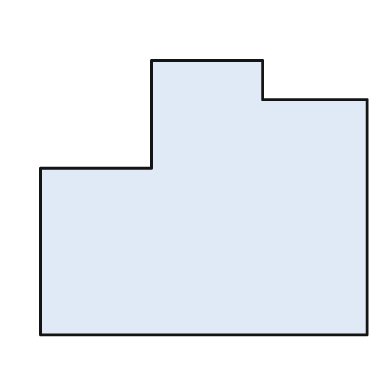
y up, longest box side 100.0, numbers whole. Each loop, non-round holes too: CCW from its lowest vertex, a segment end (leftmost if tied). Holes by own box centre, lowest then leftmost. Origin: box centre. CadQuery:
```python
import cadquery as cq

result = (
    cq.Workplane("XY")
    .moveTo(-50.0, -42.0)
    .lineTo(50.0, -42.0)
    .lineTo(50.0, 30.0)
    .lineTo(18.0, 30.0)
    .lineTo(18.0, 42.0)
    .lineTo(-16.0, 42.0)
    .lineTo(-16.0, 9.0)
    .lineTo(-50.0, 9.0)
    .close()
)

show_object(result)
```